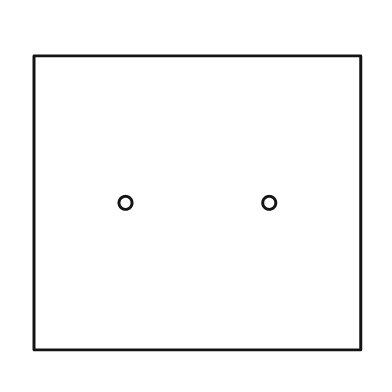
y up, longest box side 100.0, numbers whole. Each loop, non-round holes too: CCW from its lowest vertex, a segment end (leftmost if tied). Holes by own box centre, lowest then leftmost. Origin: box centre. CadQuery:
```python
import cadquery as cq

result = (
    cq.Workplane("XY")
    .moveTo(-50.0, -45.0)
    .lineTo(50.0, -45.0)
    .lineTo(50.0, 45.0)
    .lineTo(-50.0, 45.0)
    .close()
    .moveTo(-22.0, 0.0)
    .circle(2.0)
    .moveTo(22.0, 0.0)
    .circle(2.0)
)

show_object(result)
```